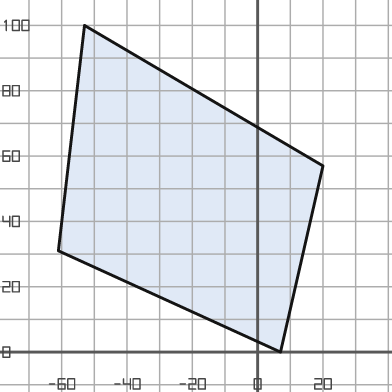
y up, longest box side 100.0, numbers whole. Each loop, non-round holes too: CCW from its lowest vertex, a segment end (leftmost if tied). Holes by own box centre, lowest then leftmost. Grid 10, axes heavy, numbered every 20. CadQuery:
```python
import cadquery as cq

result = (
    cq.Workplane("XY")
    .moveTo(7.0, 0.0)
    .lineTo(20.0, 57.0)
    .lineTo(-53.0, 100.0)
    .lineTo(-61.0, 31.0)
    .close()
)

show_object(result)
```